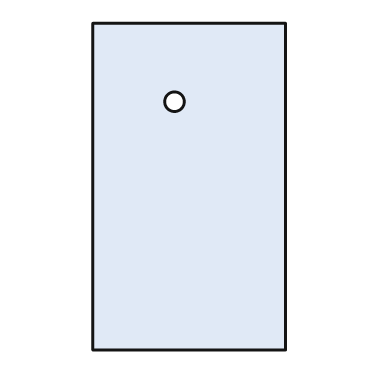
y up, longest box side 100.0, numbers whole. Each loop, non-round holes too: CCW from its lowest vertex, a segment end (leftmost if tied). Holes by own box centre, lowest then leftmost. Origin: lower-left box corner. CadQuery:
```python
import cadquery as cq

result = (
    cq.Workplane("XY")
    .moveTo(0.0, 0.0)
    .lineTo(59.0, 0.0)
    .lineTo(59.0, 100.0)
    .lineTo(0.0, 100.0)
    .close()
    .moveTo(25.0, 76.0)
    .circle(3.0)
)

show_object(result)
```